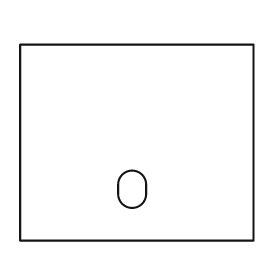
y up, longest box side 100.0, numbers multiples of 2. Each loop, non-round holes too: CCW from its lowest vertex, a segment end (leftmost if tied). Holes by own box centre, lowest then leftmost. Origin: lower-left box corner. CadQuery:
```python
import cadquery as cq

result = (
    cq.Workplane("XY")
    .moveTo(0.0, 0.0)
    .lineTo(100.0, 0.0)
    .lineTo(100.0, 84.0)
    .lineTo(0.0, 84.0)
    .close()
    .moveTo(42.0, 20.0)
    .threePointArc((48.0, 14.0), (54.0, 20.0))
    .lineTo(54.0, 24.0)
    .threePointArc((48.0, 30.0), (42.0, 24.0))
    .close()
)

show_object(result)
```